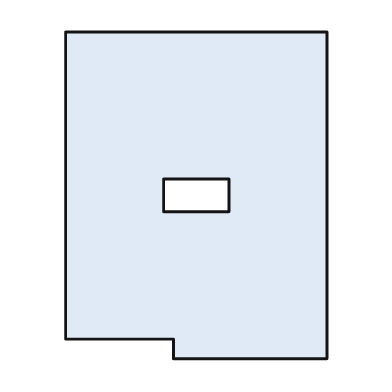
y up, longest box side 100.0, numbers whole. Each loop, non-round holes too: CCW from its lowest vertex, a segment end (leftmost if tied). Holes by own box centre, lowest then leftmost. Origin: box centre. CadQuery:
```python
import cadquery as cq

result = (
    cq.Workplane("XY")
    .moveTo(-7.0, -50.0)
    .lineTo(40.0, -50.0)
    .lineTo(40.0, 50.0)
    .lineTo(-40.0, 50.0)
    .lineTo(-40.0, -44.0)
    .lineTo(-7.0, -44.0)
    .close()
    .moveTo(-10.0, -5.0)
    .lineTo(10.0, -5.0)
    .lineTo(10.0, 5.0)
    .lineTo(-10.0, 5.0)
    .close()
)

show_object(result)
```